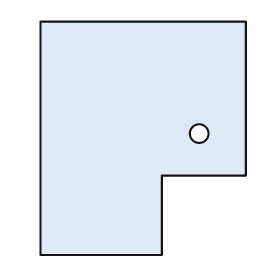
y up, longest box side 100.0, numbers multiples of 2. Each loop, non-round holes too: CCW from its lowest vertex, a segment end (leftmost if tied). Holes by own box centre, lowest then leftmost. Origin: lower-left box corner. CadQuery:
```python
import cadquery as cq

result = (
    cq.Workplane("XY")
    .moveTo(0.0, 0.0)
    .lineTo(52.0, 0.0)
    .lineTo(52.0, 34.0)
    .lineTo(88.0, 34.0)
    .lineTo(88.0, 100.0)
    .lineTo(0.0, 100.0)
    .close()
    .moveTo(68.0, 52.0)
    .circle(4.0)
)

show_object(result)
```